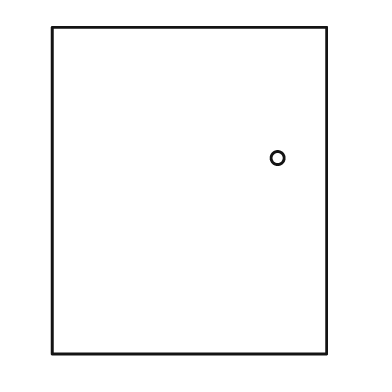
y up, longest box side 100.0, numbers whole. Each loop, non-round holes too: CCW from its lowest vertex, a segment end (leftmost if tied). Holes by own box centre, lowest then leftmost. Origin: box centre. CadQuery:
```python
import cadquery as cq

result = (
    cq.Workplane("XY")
    .moveTo(-42.0, -50.0)
    .lineTo(42.0, -50.0)
    .lineTo(42.0, 50.0)
    .lineTo(-42.0, 50.0)
    .close()
    .moveTo(27.0, 10.0)
    .circle(2.0)
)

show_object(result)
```